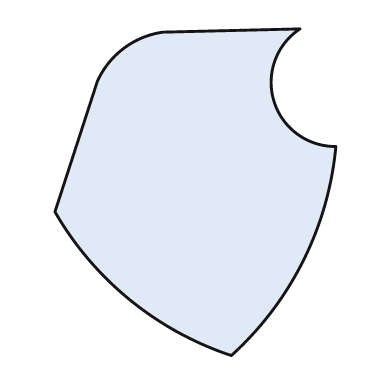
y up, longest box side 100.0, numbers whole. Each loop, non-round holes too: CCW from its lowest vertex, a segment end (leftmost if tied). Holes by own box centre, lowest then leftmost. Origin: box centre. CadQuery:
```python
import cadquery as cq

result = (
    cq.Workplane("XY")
    .moveTo(11.0, -50.0)
    .threePointArc((33.0, -21.0), (43.0, 14.0))
    .threePointArc((24.0, 28.0), (32.0, 50.0))
    .lineTo(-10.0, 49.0)
    .threePointArc((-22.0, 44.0), (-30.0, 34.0))
    .lineTo(-43.0, -6.0)
    .threePointArc((-20.0, -33.0), (11.0, -50.0))
    .close()
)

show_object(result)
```